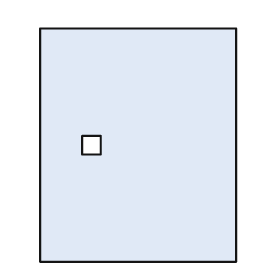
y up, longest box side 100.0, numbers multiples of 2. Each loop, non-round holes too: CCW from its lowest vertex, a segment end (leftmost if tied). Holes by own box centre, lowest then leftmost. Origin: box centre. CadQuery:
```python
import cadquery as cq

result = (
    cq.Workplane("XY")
    .moveTo(-42.0, -50.0)
    .lineTo(42.0, -50.0)
    .lineTo(42.0, 50.0)
    .lineTo(-42.0, 50.0)
    .close()
    .moveTo(-24.0, -4.0)
    .lineTo(-16.0, -4.0)
    .lineTo(-16.0, 4.0)
    .lineTo(-24.0, 4.0)
    .close()
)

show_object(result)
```